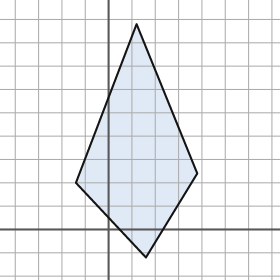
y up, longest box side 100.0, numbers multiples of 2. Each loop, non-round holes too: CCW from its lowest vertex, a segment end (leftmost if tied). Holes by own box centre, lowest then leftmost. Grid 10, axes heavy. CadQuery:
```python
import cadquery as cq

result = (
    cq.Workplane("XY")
    .moveTo(16.0, -12.0)
    .lineTo(38.0, 24.0)
    .lineTo(12.0, 88.0)
    .lineTo(-14.0, 20.0)
    .close()
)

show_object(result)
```